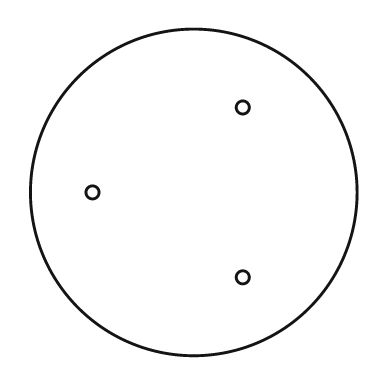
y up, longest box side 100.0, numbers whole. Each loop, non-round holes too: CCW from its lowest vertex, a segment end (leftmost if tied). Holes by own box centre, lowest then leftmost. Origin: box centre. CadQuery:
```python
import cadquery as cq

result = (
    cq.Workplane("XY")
    .moveTo(0.0, 0.0)
    .circle(50.0)
    .moveTo(15.0, -26.0)
    .circle(2.0)
    .moveTo(-31.0, 0.0)
    .circle(2.0)
    .moveTo(15.0, 26.0)
    .circle(2.0)
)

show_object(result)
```